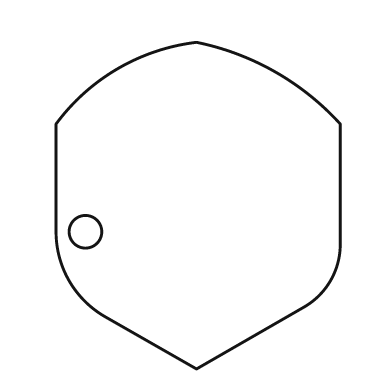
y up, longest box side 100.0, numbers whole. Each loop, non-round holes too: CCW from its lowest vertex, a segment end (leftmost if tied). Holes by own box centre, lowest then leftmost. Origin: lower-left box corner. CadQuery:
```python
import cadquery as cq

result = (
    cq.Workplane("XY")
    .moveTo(43.0, 0.0)
    .lineTo(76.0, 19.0)
    .threePointArc((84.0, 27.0), (87.0, 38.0))
    .lineTo(87.0, 75.0)
    .threePointArc((67.0, 91.0), (43.0, 100.0))
    .threePointArc((19.0, 92.0), (0.0, 75.0))
    .lineTo(0.0, 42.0)
    .threePointArc((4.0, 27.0), (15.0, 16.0))
    .close()
    .moveTo(9.0, 42.0)
    .circle(5.0)
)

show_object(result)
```